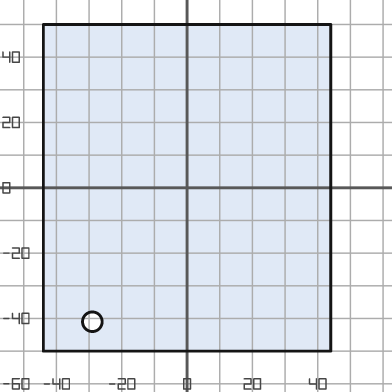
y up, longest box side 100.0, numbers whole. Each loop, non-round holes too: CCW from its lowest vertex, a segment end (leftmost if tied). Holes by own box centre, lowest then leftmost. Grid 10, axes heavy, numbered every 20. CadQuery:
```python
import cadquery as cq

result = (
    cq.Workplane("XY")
    .moveTo(-44.0, -50.0)
    .lineTo(44.0, -50.0)
    .lineTo(44.0, 50.0)
    .lineTo(-44.0, 50.0)
    .close()
    .moveTo(-29.0, -41.0)
    .circle(3.0)
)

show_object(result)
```